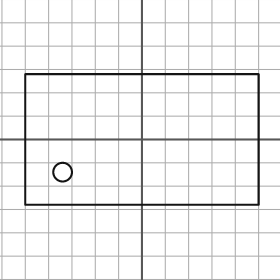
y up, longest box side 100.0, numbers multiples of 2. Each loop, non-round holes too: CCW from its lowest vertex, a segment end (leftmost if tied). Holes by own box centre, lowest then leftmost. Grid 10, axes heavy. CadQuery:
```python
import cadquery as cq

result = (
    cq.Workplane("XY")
    .moveTo(-50.0, -28.0)
    .lineTo(50.0, -28.0)
    .lineTo(50.0, 28.0)
    .lineTo(-50.0, 28.0)
    .close()
    .moveTo(-34.0, -14.0)
    .circle(4.0)
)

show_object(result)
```